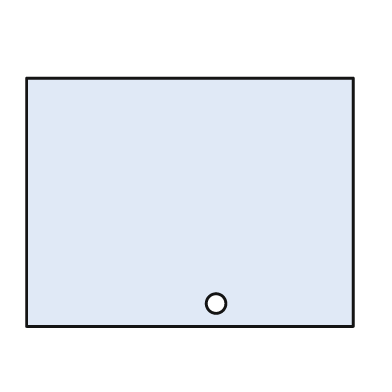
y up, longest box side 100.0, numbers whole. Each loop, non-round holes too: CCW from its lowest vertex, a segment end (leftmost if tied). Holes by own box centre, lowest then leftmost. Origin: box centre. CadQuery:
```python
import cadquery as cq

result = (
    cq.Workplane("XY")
    .moveTo(-50.0, -38.0)
    .lineTo(50.0, -38.0)
    .lineTo(50.0, 38.0)
    .lineTo(-50.0, 38.0)
    .close()
    .moveTo(8.0, -31.0)
    .circle(3.0)
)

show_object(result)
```